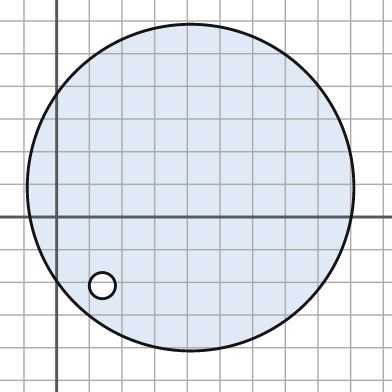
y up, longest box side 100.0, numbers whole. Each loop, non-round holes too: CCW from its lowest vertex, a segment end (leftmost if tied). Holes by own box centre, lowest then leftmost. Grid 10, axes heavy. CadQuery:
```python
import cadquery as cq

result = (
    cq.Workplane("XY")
    .moveTo(41.0, 9.0)
    .circle(50.0)
    .moveTo(14.0, -21.0)
    .circle(4.0)
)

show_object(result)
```